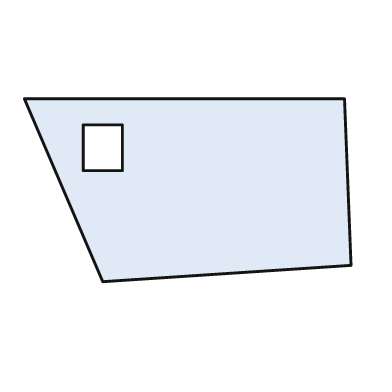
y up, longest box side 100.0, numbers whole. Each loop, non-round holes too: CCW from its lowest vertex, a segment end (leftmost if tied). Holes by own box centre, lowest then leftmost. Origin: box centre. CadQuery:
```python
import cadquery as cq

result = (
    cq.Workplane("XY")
    .moveTo(-26.0, -28.0)
    .lineTo(50.0, -23.0)
    .lineTo(48.0, 28.0)
    .lineTo(-50.0, 28.0)
    .close()
    .moveTo(-32.0, 6.0)
    .lineTo(-20.0, 6.0)
    .lineTo(-20.0, 20.0)
    .lineTo(-32.0, 20.0)
    .close()
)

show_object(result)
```